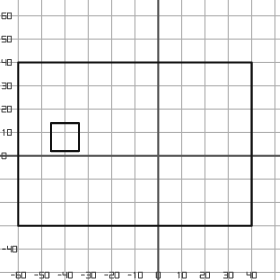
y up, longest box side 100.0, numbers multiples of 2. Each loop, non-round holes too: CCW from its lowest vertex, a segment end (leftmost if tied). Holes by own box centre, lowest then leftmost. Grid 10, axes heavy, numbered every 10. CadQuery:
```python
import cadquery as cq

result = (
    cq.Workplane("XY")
    .moveTo(-60.0, -30.0)
    .lineTo(40.0, -30.0)
    .lineTo(40.0, 40.0)
    .lineTo(-60.0, 40.0)
    .close()
    .moveTo(-46.0, 2.0)
    .lineTo(-34.0, 2.0)
    .lineTo(-34.0, 14.0)
    .lineTo(-46.0, 14.0)
    .close()
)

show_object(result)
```